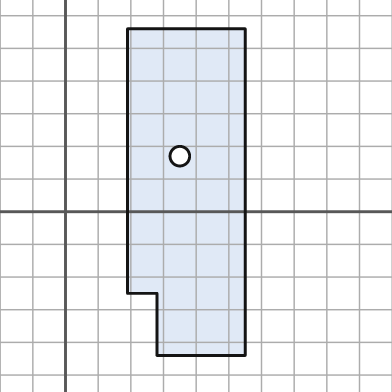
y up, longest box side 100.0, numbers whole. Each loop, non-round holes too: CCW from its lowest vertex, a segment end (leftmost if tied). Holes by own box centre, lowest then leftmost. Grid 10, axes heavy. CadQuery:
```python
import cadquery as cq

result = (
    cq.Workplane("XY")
    .moveTo(28.0, -44.0)
    .lineTo(55.0, -44.0)
    .lineTo(55.0, 56.0)
    .lineTo(19.0, 56.0)
    .lineTo(19.0, -25.0)
    .lineTo(28.0, -25.0)
    .close()
    .moveTo(35.0, 17.0)
    .circle(3.0)
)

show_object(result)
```